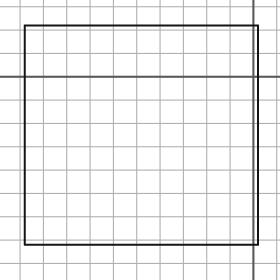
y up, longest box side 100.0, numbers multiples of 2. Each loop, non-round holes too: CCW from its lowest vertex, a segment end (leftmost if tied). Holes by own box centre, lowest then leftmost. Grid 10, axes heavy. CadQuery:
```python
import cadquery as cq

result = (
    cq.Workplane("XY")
    .moveTo(-98.0, -72.0)
    .lineTo(2.0, -72.0)
    .lineTo(2.0, 22.0)
    .lineTo(-98.0, 22.0)
    .close()
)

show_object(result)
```